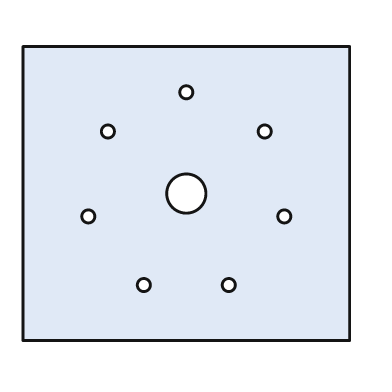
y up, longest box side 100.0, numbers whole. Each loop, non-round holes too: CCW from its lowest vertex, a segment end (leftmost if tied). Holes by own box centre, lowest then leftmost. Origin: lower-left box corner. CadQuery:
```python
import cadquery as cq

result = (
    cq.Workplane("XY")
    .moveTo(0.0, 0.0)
    .lineTo(100.0, 0.0)
    .lineTo(100.0, 90.0)
    .lineTo(0.0, 90.0)
    .close()
    .moveTo(37.0, 17.0)
    .circle(2.0)
    .moveTo(63.0, 17.0)
    .circle(2.0)
    .moveTo(20.0, 38.0)
    .circle(2.0)
    .moveTo(80.0, 38.0)
    .circle(2.0)
    .moveTo(50.0, 45.0)
    .circle(6.0)
    .moveTo(26.0, 64.0)
    .circle(2.0)
    .moveTo(74.0, 64.0)
    .circle(2.0)
    .moveTo(50.0, 76.0)
    .circle(2.0)
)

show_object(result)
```